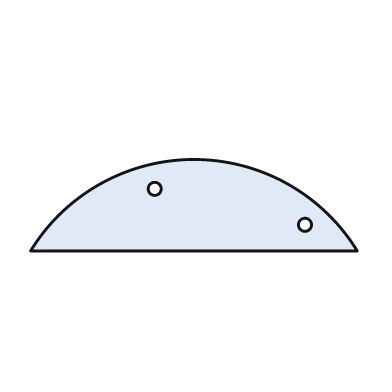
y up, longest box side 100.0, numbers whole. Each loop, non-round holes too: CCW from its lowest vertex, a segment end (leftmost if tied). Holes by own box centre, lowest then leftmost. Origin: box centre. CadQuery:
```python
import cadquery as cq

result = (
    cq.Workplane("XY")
    .moveTo(-50.0, -14.0)
    .lineTo(50.0, -14.0)
    .threePointArc((0.0, 14.0), (-50.0, -14.0))
    .close()
    .moveTo(34.0, -6.0)
    .circle(2.0)
    .moveTo(-12.0, 5.0)
    .circle(2.0)
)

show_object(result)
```